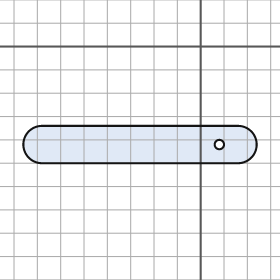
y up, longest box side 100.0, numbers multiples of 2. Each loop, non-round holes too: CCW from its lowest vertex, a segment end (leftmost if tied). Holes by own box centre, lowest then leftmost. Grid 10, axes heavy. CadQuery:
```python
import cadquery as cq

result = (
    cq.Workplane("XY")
    .moveTo(-68.0, -50.0)
    .lineTo(16.0, -50.0)
    .threePointArc((24.0, -42.0), (16.0, -34.0))
    .lineTo(-68.0, -34.0)
    .threePointArc((-76.0, -42.0), (-68.0, -50.0))
    .close()
    .moveTo(8.0, -42.0)
    .circle(2.0)
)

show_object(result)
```